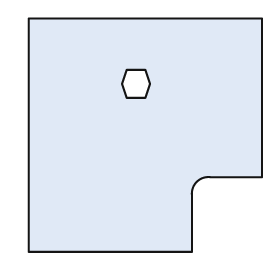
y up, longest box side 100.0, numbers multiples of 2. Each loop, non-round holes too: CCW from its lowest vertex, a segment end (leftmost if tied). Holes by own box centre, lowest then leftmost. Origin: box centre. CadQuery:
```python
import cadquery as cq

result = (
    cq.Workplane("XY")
    .moveTo(-50.0, -50.0)
    .lineTo(20.0, -50.0)
    .lineTo(20.0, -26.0)
    .threePointArc((22.0, -20.0), (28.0, -18.0))
    .lineTo(50.0, -18.0)
    .lineTo(50.0, 50.0)
    .lineTo(-50.0, 50.0)
    .close()
    .moveTo(-8.0, 16.0)
    .lineTo(0.0, 16.0)
    .lineTo(2.0, 22.0)
    .lineTo(0.0, 28.0)
    .lineTo(-8.0, 28.0)
    .lineTo(-10.0, 22.0)
    .close()
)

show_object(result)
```